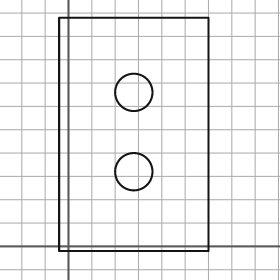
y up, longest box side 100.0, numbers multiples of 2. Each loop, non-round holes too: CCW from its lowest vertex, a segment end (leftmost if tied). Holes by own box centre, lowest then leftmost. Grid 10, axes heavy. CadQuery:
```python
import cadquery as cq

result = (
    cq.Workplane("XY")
    .moveTo(-4.0, -2.0)
    .lineTo(60.0, -2.0)
    .lineTo(60.0, 98.0)
    .lineTo(-4.0, 98.0)
    .close()
    .moveTo(28.0, 32.0)
    .circle(8.0)
    .moveTo(28.0, 66.0)
    .circle(8.0)
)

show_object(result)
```